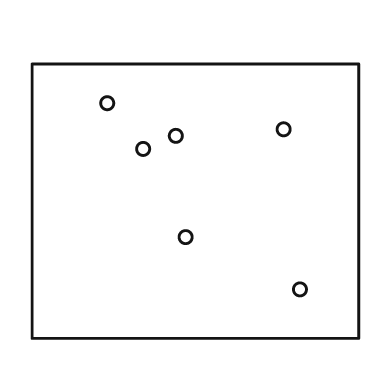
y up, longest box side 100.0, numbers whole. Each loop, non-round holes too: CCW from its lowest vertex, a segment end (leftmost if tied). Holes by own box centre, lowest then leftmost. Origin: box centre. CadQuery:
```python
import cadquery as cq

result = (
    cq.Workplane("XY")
    .moveTo(-50.0, -42.0)
    .lineTo(50.0, -42.0)
    .lineTo(50.0, 42.0)
    .lineTo(-50.0, 42.0)
    .close()
    .moveTo(32.0, -27.0)
    .circle(2.0)
    .moveTo(-3.0, -11.0)
    .circle(2.0)
    .moveTo(-16.0, 16.0)
    .circle(2.0)
    .moveTo(-6.0, 20.0)
    .circle(2.0)
    .moveTo(27.0, 22.0)
    .circle(2.0)
    .moveTo(-27.0, 30.0)
    .circle(2.0)
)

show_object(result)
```